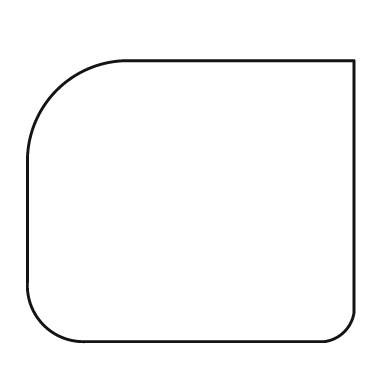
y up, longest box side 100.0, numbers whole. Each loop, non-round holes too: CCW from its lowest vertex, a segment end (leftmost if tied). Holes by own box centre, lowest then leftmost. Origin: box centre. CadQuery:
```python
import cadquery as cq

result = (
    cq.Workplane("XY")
    .moveTo(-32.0, -43.0)
    .lineTo(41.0, -43.0)
    .threePointArc((47.0, -40.0), (50.0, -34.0))
    .lineTo(50.0, 43.0)
    .lineTo(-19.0, 43.0)
    .threePointArc((-41.0, 34.0), (-50.0, 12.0))
    .lineTo(-50.0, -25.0)
    .threePointArc((-45.0, -38.0), (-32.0, -43.0))
    .close()
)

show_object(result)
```